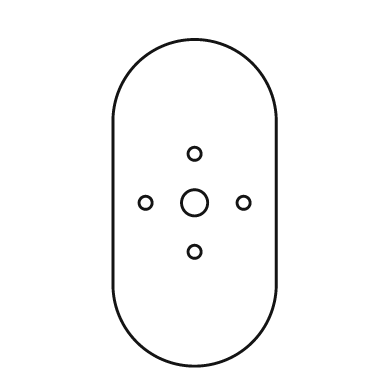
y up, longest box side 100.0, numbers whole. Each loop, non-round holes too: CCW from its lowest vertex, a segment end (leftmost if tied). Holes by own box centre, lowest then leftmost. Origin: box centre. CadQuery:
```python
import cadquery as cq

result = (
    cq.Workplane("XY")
    .moveTo(-25.0, -25.0)
    .threePointArc((0.0, -50.0), (25.0, -25.0))
    .lineTo(25.0, 25.0)
    .threePointArc((0.0, 50.0), (-25.0, 25.0))
    .close()
    .moveTo(0.0, -15.0)
    .circle(2.0)
    .moveTo(-15.0, 0.0)
    .circle(2.0)
    .moveTo(0.0, 0.0)
    .circle(4.0)
    .moveTo(15.0, 0.0)
    .circle(2.0)
    .moveTo(0.0, 15.0)
    .circle(2.0)
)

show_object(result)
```